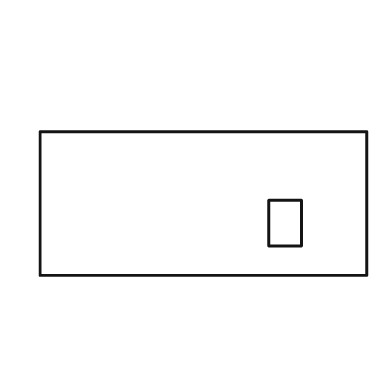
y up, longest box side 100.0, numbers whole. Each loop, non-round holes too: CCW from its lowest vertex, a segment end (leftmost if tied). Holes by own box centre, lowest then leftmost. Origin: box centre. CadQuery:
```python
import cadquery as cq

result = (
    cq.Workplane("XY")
    .moveTo(-50.0, -22.0)
    .lineTo(50.0, -22.0)
    .lineTo(50.0, 22.0)
    .lineTo(-50.0, 22.0)
    .close()
    .moveTo(20.0, -13.0)
    .lineTo(30.0, -13.0)
    .lineTo(30.0, 1.0)
    .lineTo(20.0, 1.0)
    .close()
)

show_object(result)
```